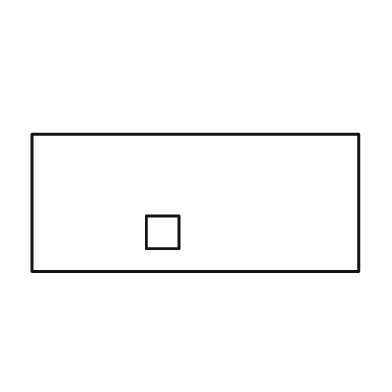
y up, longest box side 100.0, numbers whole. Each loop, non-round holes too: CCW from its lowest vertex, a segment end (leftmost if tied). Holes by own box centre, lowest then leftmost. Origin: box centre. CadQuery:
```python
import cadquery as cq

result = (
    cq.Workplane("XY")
    .moveTo(-50.0, -21.0)
    .lineTo(50.0, -21.0)
    .lineTo(50.0, 21.0)
    .lineTo(-50.0, 21.0)
    .close()
    .moveTo(-15.0, -14.0)
    .lineTo(-5.0, -14.0)
    .lineTo(-5.0, -4.0)
    .lineTo(-15.0, -4.0)
    .close()
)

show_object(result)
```